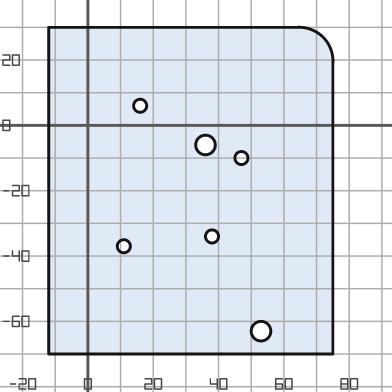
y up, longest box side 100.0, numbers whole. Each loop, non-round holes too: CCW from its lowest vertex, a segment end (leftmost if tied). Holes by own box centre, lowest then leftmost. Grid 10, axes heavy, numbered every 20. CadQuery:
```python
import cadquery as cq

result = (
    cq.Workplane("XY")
    .moveTo(-12.0, -70.0)
    .lineTo(75.0, -70.0)
    .lineTo(75.0, 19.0)
    .threePointArc((72.0, 27.0), (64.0, 30.0))
    .lineTo(-12.0, 30.0)
    .close()
    .moveTo(53.0, -63.0)
    .circle(3.0)
    .moveTo(11.0, -37.0)
    .circle(2.0)
    .moveTo(38.0, -34.0)
    .circle(2.0)
    .moveTo(47.0, -10.0)
    .circle(2.0)
    .moveTo(36.0, -6.0)
    .circle(3.0)
    .moveTo(16.0, 6.0)
    .circle(2.0)
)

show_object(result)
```